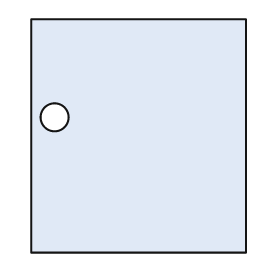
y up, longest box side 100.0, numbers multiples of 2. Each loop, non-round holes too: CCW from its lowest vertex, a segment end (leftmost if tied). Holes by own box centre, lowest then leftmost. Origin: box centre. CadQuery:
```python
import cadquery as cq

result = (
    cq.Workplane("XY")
    .moveTo(-46.0, -50.0)
    .lineTo(46.0, -50.0)
    .lineTo(46.0, 50.0)
    .lineTo(-46.0, 50.0)
    .close()
    .moveTo(-36.0, 8.0)
    .circle(6.0)
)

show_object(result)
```